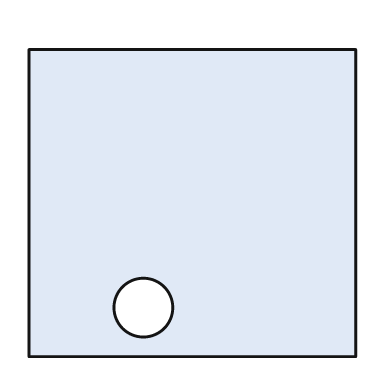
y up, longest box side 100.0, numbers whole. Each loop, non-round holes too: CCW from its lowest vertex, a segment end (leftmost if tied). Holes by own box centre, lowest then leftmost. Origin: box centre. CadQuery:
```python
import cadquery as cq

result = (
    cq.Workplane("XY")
    .moveTo(-50.0, -47.0)
    .lineTo(50.0, -47.0)
    .lineTo(50.0, 47.0)
    .lineTo(-50.0, 47.0)
    .close()
    .moveTo(-15.0, -32.0)
    .circle(9.0)
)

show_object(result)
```